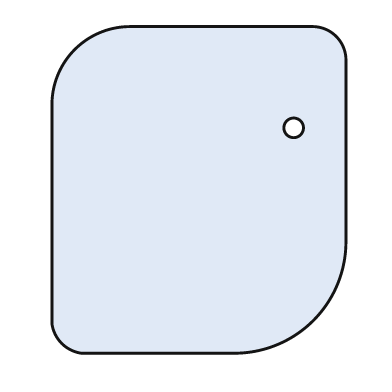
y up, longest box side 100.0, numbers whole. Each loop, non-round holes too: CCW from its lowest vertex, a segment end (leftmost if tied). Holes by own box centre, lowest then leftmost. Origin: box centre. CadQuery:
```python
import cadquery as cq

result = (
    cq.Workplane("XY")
    .moveTo(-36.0, -50.0)
    .lineTo(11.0, -50.0)
    .threePointArc((35.0, -40.0), (45.0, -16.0))
    .lineTo(45.0, 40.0)
    .threePointArc((42.0, 47.0), (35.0, 50.0))
    .lineTo(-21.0, 50.0)
    .threePointArc((-38.0, 43.0), (-45.0, 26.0))
    .lineTo(-45.0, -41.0)
    .threePointArc((-42.0, -47.0), (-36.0, -50.0))
    .close()
    .moveTo(29.0, 19.0)
    .circle(3.0)
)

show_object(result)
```